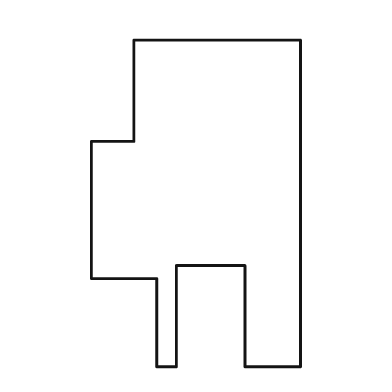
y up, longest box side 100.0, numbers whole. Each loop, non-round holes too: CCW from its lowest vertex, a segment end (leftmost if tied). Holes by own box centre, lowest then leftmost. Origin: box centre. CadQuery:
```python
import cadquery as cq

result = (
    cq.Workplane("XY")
    .moveTo(-12.0, -50.0)
    .lineTo(-6.0, -50.0)
    .lineTo(-6.0, -19.0)
    .lineTo(15.0, -19.0)
    .lineTo(15.0, -50.0)
    .lineTo(32.0, -50.0)
    .lineTo(32.0, 50.0)
    .lineTo(-19.0, 50.0)
    .lineTo(-19.0, 19.0)
    .lineTo(-32.0, 19.0)
    .lineTo(-32.0, -23.0)
    .lineTo(-12.0, -23.0)
    .close()
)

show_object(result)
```